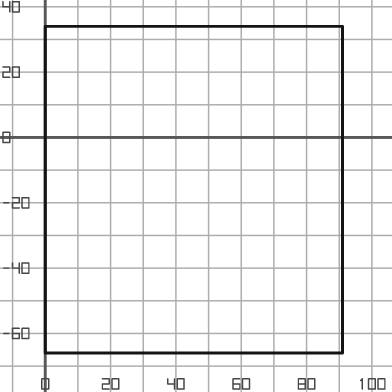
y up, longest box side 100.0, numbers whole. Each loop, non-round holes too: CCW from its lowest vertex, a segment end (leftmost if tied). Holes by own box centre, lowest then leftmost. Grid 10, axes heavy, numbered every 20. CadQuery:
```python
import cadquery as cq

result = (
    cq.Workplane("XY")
    .moveTo(0.0, -66.0)
    .lineTo(91.0, -66.0)
    .lineTo(91.0, 34.0)
    .lineTo(0.0, 34.0)
    .close()
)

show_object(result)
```